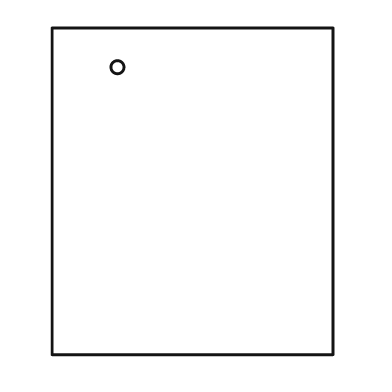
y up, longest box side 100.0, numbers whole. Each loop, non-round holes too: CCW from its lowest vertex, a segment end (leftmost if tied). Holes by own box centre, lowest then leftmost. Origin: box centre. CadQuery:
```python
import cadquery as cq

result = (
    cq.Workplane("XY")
    .moveTo(-43.0, -50.0)
    .lineTo(43.0, -50.0)
    .lineTo(43.0, 50.0)
    .lineTo(-43.0, 50.0)
    .close()
    .moveTo(-23.0, 38.0)
    .circle(2.0)
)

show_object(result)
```